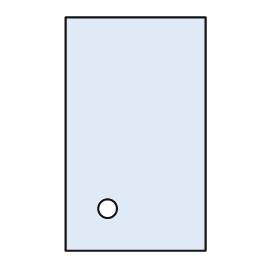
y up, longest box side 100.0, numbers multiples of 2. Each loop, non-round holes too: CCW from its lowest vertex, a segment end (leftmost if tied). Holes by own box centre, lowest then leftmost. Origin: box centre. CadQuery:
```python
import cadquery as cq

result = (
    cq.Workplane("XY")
    .moveTo(-30.0, -50.0)
    .lineTo(30.0, -50.0)
    .lineTo(30.0, 50.0)
    .lineTo(-30.0, 50.0)
    .close()
    .moveTo(-12.0, -32.0)
    .circle(4.0)
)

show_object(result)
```